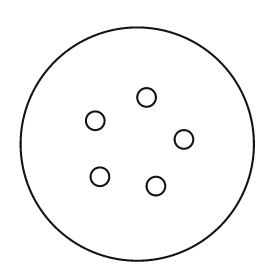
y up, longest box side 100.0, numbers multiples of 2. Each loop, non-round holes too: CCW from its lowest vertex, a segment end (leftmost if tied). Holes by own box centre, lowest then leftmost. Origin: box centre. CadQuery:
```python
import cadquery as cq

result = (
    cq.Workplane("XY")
    .moveTo(0.0, 0.0)
    .circle(50.0)
    .moveTo(8.0, -18.0)
    .circle(4.0)
    .moveTo(-16.0, -14.0)
    .circle(4.0)
    .moveTo(20.0, 2.0)
    .circle(4.0)
    .moveTo(-18.0, 10.0)
    .circle(4.0)
    .moveTo(4.0, 20.0)
    .circle(4.0)
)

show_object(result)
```